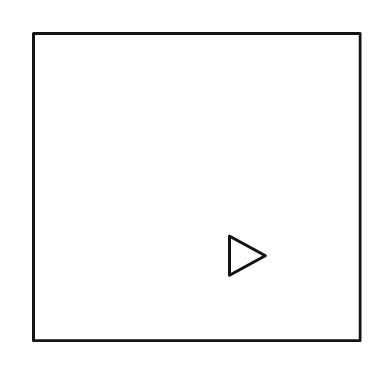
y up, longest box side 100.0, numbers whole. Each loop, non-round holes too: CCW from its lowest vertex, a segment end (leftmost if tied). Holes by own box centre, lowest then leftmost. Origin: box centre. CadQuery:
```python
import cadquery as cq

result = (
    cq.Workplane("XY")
    .moveTo(-50.0, -47.0)
    .lineTo(50.0, -47.0)
    .lineTo(50.0, 47.0)
    .lineTo(-50.0, 47.0)
    .close()
    .moveTo(10.0, -27.0)
    .lineTo(21.0, -21.0)
    .lineTo(10.0, -15.0)
    .close()
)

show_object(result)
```